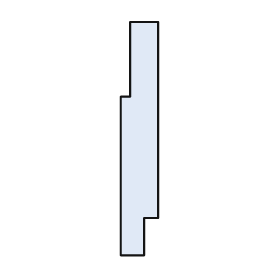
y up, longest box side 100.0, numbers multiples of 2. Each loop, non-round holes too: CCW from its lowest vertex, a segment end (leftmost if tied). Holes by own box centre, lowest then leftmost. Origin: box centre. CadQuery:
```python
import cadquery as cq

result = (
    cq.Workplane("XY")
    .moveTo(-8.0, -50.0)
    .lineTo(2.0, -50.0)
    .lineTo(2.0, -34.0)
    .lineTo(8.0, -34.0)
    .lineTo(8.0, 50.0)
    .lineTo(-4.0, 50.0)
    .lineTo(-4.0, 18.0)
    .lineTo(-8.0, 18.0)
    .close()
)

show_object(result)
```